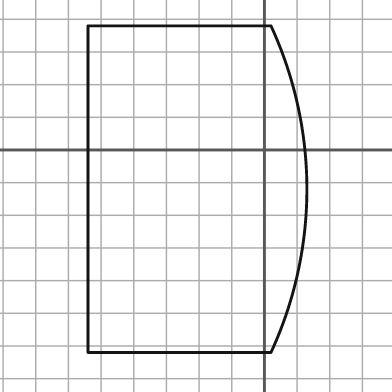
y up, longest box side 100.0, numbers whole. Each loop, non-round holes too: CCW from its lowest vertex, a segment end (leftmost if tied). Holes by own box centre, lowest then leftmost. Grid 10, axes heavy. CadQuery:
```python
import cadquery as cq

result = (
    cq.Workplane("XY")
    .moveTo(-54.0, -62.0)
    .lineTo(2.0, -62.0)
    .threePointArc((13.0, -12.0), (2.0, 38.0))
    .lineTo(-54.0, 38.0)
    .close()
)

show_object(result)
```